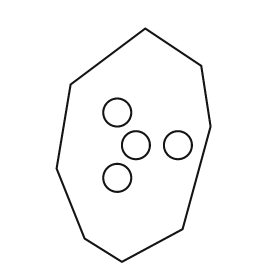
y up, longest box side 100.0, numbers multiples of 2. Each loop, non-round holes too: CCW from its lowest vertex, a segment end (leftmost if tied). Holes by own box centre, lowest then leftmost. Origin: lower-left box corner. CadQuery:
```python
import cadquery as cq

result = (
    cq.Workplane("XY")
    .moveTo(28.0, 0.0)
    .lineTo(54.0, 14.0)
    .lineTo(66.0, 58.0)
    .lineTo(62.0, 84.0)
    .lineTo(38.0, 100.0)
    .lineTo(6.0, 76.0)
    .lineTo(0.0, 40.0)
    .lineTo(12.0, 10.0)
    .close()
    .moveTo(26.0, 36.0)
    .circle(6.0)
    .moveTo(34.0, 50.0)
    .circle(6.0)
    .moveTo(52.0, 50.0)
    .circle(6.0)
    .moveTo(26.0, 64.0)
    .circle(6.0)
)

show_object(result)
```